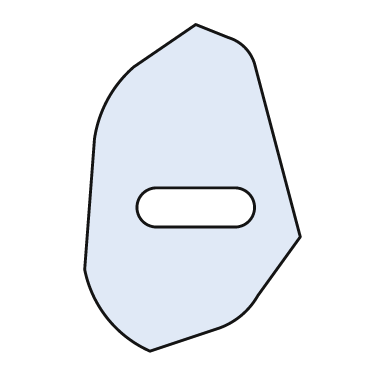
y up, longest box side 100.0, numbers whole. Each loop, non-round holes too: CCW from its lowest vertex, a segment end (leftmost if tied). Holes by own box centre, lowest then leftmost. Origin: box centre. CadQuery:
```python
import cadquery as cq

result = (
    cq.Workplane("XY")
    .moveTo(-13.0, -50.0)
    .lineTo(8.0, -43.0)
    .threePointArc((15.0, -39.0), (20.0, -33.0))
    .lineTo(33.0, -15.0)
    .lineTo(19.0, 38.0)
    .threePointArc((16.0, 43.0), (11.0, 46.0))
    .lineTo(1.0, 50.0)
    .lineTo(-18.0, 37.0)
    .threePointArc((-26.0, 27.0), (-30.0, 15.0))
    .lineTo(-33.0, -25.0)
    .threePointArc((-26.0, -40.0), (-13.0, -50.0))
    .close()
    .moveTo(-11.0, -12.0)
    .lineTo(13.0, -12.0)
    .threePointArc((19.0, -6.0), (13.0, 0.0))
    .lineTo(-11.0, 0.0)
    .threePointArc((-17.0, -6.0), (-11.0, -12.0))
    .close()
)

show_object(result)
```